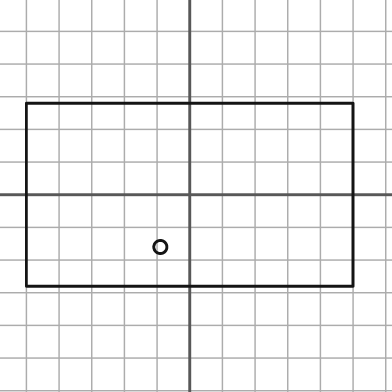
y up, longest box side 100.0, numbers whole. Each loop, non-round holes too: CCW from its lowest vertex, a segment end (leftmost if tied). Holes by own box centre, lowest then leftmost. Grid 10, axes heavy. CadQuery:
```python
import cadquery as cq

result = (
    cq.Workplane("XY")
    .moveTo(-50.0, -28.0)
    .lineTo(50.0, -28.0)
    .lineTo(50.0, 28.0)
    .lineTo(-50.0, 28.0)
    .close()
    .moveTo(-9.0, -16.0)
    .circle(2.0)
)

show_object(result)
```